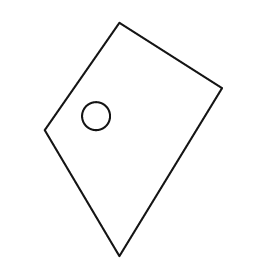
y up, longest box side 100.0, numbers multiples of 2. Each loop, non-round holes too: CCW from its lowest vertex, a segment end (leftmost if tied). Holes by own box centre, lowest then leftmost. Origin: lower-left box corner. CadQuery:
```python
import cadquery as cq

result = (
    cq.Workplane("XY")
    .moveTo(32.0, 0.0)
    .lineTo(76.0, 72.0)
    .lineTo(32.0, 100.0)
    .lineTo(0.0, 54.0)
    .close()
    .moveTo(22.0, 60.0)
    .circle(6.0)
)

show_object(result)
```